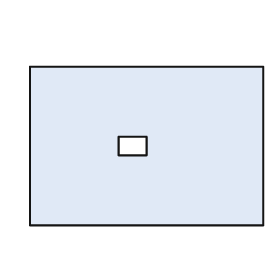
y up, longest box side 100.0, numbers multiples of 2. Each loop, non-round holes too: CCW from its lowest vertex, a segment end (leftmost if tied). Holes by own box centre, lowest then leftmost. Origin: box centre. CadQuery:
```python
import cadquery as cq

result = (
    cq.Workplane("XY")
    .moveTo(-50.0, -34.0)
    .lineTo(50.0, -34.0)
    .lineTo(50.0, 34.0)
    .lineTo(-50.0, 34.0)
    .close()
    .moveTo(-12.0, -4.0)
    .lineTo(0.0, -4.0)
    .lineTo(0.0, 4.0)
    .lineTo(-12.0, 4.0)
    .close()
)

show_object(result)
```